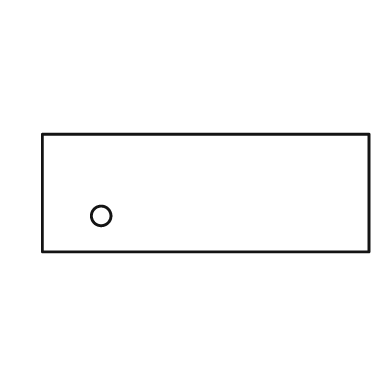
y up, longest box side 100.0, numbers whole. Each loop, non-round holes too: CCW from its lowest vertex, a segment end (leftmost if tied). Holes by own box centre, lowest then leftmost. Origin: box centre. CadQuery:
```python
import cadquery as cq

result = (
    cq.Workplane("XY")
    .moveTo(-50.0, -18.0)
    .lineTo(50.0, -18.0)
    .lineTo(50.0, 18.0)
    .lineTo(-50.0, 18.0)
    .close()
    .moveTo(-32.0, -7.0)
    .circle(3.0)
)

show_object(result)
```